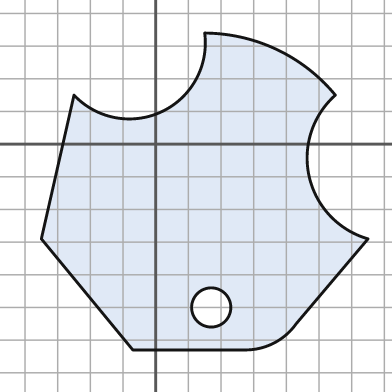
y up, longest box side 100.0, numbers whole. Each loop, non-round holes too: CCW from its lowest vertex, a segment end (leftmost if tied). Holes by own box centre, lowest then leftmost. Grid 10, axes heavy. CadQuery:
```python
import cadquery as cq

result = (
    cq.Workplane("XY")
    .moveTo(-7.0, -63.0)
    .lineTo(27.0, -63.0)
    .threePointArc((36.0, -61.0), (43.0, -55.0))
    .lineTo(65.0, -29.0)
    .threePointArc((47.0, -10.0), (55.0, 15.0))
    .threePointArc((37.0, 29.0), (15.0, 34.0))
    .threePointArc((2.0, 10.0), (-25.0, 15.0))
    .lineTo(-35.0, -29.0)
    .close()
    .moveTo(17.0, -50.0)
    .circle(6.0)
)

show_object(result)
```